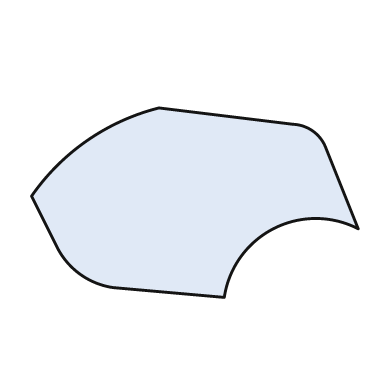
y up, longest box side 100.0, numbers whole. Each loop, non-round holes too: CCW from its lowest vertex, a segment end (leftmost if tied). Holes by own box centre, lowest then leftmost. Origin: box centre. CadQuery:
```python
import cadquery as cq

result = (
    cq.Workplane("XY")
    .moveTo(9.0, -29.0)
    .threePointArc((24.0, -8.0), (50.0, -8.0))
    .lineTo(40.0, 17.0)
    .threePointArc((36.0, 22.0), (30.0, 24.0))
    .lineTo(-11.0, 29.0)
    .threePointArc((-33.0, 19.0), (-50.0, 2.0))
    .lineTo(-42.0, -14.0)
    .threePointArc((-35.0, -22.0), (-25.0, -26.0))
    .close()
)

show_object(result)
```